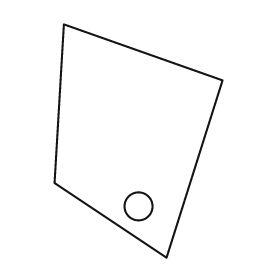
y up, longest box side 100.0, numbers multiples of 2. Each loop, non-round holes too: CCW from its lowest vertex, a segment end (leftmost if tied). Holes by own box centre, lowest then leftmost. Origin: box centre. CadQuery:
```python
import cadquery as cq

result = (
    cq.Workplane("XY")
    .moveTo(12.0, -50.0)
    .lineTo(36.0, 26.0)
    .lineTo(-32.0, 50.0)
    .lineTo(-36.0, -18.0)
    .close()
    .moveTo(0.0, -28.0)
    .circle(6.0)
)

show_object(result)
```